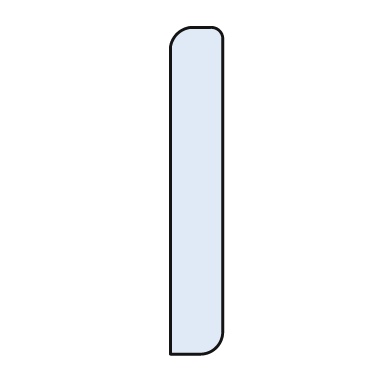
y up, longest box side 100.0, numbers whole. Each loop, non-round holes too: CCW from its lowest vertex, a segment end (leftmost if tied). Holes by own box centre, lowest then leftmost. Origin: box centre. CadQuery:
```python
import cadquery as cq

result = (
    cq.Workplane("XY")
    .moveTo(-8.0, -50.0)
    .lineTo(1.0, -50.0)
    .threePointArc((6.0, -48.0), (8.0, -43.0))
    .lineTo(8.0, 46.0)
    .threePointArc((7.0, 49.0), (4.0, 50.0))
    .lineTo(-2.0, 50.0)
    .threePointArc((-6.0, 48.0), (-8.0, 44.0))
    .close()
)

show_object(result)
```